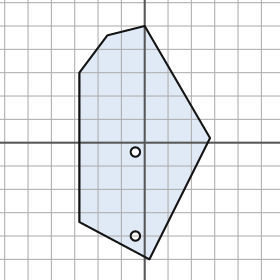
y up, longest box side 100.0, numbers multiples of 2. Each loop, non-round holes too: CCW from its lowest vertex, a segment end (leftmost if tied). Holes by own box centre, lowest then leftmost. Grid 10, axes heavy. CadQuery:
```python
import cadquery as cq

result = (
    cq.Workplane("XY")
    .moveTo(2.0, -50.0)
    .lineTo(28.0, 2.0)
    .lineTo(0.0, 50.0)
    .lineTo(-16.0, 46.0)
    .lineTo(-28.0, 30.0)
    .lineTo(-28.0, -34.0)
    .close()
    .moveTo(-4.0, -40.0)
    .circle(2.0)
    .moveTo(-4.0, -4.0)
    .circle(2.0)
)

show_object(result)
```